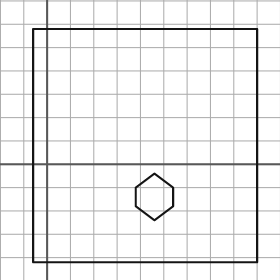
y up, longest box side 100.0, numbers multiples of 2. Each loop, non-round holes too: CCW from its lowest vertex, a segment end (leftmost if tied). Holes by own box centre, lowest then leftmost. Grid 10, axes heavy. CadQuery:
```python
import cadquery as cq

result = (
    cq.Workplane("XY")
    .moveTo(-6.0, -42.0)
    .lineTo(90.0, -42.0)
    .lineTo(90.0, 58.0)
    .lineTo(-6.0, 58.0)
    .close()
    .moveTo(46.0, -24.0)
    .lineTo(54.0, -18.0)
    .lineTo(54.0, -10.0)
    .lineTo(46.0, -4.0)
    .lineTo(38.0, -10.0)
    .lineTo(38.0, -18.0)
    .close()
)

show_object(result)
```